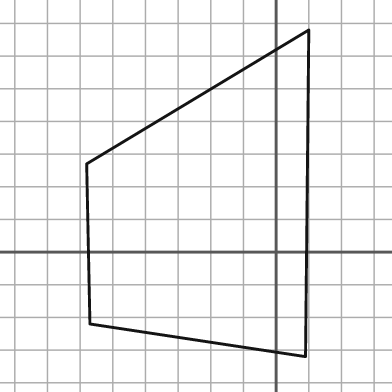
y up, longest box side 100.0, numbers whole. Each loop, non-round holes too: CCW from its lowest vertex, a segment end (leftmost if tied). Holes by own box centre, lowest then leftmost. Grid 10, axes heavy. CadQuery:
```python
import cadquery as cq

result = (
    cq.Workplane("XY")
    .moveTo(9.0, -32.0)
    .lineTo(10.0, 68.0)
    .lineTo(-58.0, 27.0)
    .lineTo(-57.0, -22.0)
    .close()
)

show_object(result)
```